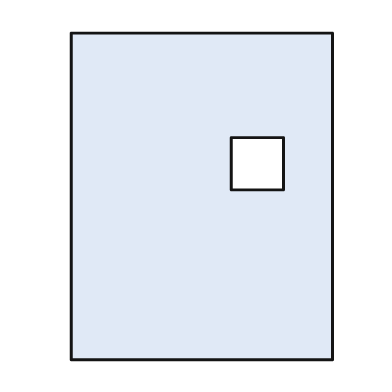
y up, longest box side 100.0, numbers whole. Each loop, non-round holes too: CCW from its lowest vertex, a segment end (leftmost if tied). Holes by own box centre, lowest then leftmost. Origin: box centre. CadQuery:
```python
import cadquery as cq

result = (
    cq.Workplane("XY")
    .moveTo(-40.0, -50.0)
    .lineTo(40.0, -50.0)
    .lineTo(40.0, 50.0)
    .lineTo(-40.0, 50.0)
    .close()
    .moveTo(9.0, 2.0)
    .lineTo(25.0, 2.0)
    .lineTo(25.0, 18.0)
    .lineTo(9.0, 18.0)
    .close()
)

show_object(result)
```